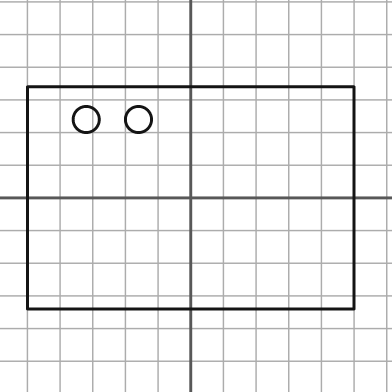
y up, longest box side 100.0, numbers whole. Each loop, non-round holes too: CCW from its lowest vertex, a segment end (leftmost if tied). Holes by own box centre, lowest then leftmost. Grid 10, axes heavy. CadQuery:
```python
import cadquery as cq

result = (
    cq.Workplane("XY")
    .moveTo(-50.0, -34.0)
    .lineTo(50.0, -34.0)
    .lineTo(50.0, 34.0)
    .lineTo(-50.0, 34.0)
    .close()
    .moveTo(-32.0, 24.0)
    .circle(4.0)
    .moveTo(-16.0, 24.0)
    .circle(4.0)
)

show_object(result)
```